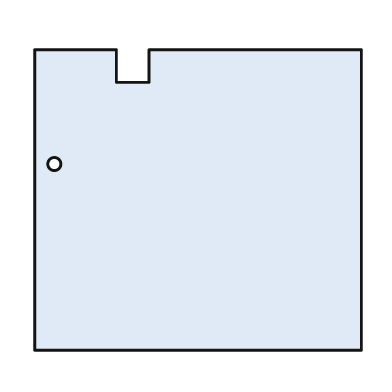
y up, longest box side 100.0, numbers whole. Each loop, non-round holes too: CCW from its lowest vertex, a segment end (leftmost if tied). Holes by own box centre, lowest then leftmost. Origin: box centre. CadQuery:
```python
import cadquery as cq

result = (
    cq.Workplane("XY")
    .moveTo(-50.0, -46.0)
    .lineTo(50.0, -46.0)
    .lineTo(50.0, 46.0)
    .lineTo(-15.0, 46.0)
    .lineTo(-15.0, 36.0)
    .lineTo(-25.0, 36.0)
    .lineTo(-25.0, 46.0)
    .lineTo(-50.0, 46.0)
    .close()
    .moveTo(-44.0, 11.0)
    .circle(2.0)
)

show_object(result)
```